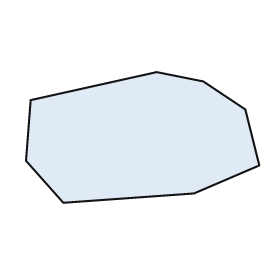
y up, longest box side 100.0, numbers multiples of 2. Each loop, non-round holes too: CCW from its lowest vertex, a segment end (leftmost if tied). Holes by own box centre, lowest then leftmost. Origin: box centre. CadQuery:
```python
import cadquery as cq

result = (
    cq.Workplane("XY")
    .moveTo(-34.0, -28.0)
    .lineTo(22.0, -24.0)
    .lineTo(50.0, -12.0)
    .lineTo(44.0, 12.0)
    .lineTo(26.0, 24.0)
    .lineTo(6.0, 28.0)
    .lineTo(-48.0, 16.0)
    .lineTo(-50.0, -10.0)
    .close()
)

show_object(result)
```